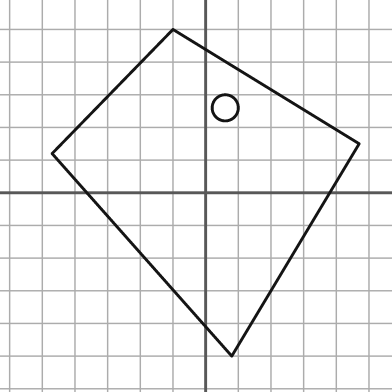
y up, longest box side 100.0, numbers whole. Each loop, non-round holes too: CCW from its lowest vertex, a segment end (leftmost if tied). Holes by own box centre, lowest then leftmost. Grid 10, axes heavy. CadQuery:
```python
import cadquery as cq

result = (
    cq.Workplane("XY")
    .moveTo(8.0, -50.0)
    .lineTo(47.0, 15.0)
    .lineTo(-10.0, 50.0)
    .lineTo(-47.0, 12.0)
    .close()
    .moveTo(6.0, 26.0)
    .circle(4.0)
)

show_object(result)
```